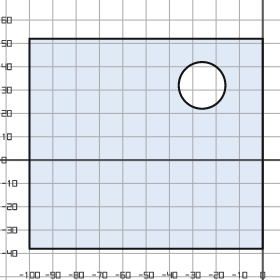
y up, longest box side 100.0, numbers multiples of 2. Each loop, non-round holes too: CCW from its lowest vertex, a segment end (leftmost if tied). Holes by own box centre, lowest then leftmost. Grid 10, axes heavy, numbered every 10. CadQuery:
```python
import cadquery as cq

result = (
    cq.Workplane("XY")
    .moveTo(-100.0, -38.0)
    .lineTo(0.0, -38.0)
    .lineTo(0.0, 52.0)
    .lineTo(-100.0, 52.0)
    .close()
    .moveTo(-26.0, 32.0)
    .circle(10.0)
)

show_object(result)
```